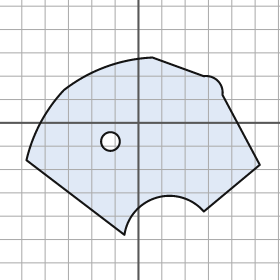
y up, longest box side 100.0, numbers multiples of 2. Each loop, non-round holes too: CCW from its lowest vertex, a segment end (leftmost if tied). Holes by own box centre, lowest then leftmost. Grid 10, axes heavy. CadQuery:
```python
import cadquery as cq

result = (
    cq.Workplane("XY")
    .moveTo(-6.0, -48.0)
    .threePointArc((8.0, -32.0), (28.0, -38.0))
    .lineTo(52.0, -18.0)
    .lineTo(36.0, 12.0)
    .threePointArc((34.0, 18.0), (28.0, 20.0))
    .lineTo(6.0, 28.0)
    .threePointArc((-14.0, 24.0), (-32.0, 14.0))
    .threePointArc((-42.0, 0.0), (-48.0, -16.0))
    .close()
    .moveTo(-12.0, -8.0)
    .circle(4.0)
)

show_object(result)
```